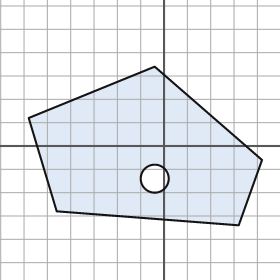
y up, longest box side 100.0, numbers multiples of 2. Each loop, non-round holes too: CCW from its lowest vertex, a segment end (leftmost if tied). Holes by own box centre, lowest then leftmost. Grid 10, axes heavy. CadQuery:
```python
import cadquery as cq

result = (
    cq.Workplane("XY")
    .moveTo(32.0, -34.0)
    .lineTo(42.0, -6.0)
    .lineTo(-4.0, 34.0)
    .lineTo(-58.0, 12.0)
    .lineTo(-46.0, -28.0)
    .close()
    .moveTo(-4.0, -14.0)
    .circle(6.0)
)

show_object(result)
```